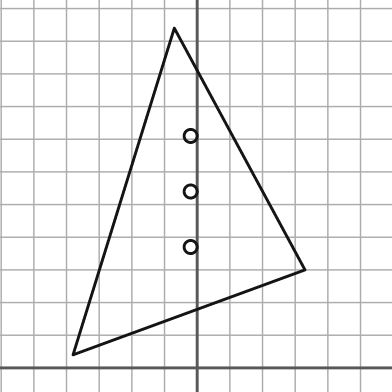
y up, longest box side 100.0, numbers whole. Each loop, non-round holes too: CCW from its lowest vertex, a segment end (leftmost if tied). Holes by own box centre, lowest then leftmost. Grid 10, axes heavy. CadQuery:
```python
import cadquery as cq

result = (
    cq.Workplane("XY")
    .moveTo(-38.0, 4.0)
    .lineTo(33.0, 30.0)
    .lineTo(-7.0, 104.0)
    .close()
    .moveTo(-2.0, 37.0)
    .circle(2.0)
    .moveTo(-2.0, 54.0)
    .circle(2.0)
    .moveTo(-2.0, 71.0)
    .circle(2.0)
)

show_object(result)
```